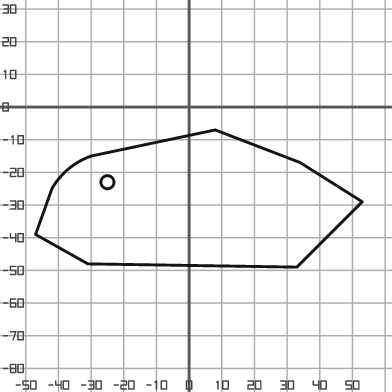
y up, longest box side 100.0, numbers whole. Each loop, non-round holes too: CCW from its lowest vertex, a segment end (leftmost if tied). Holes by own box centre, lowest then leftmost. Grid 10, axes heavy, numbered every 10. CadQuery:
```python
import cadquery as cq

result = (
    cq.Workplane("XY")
    .moveTo(33.0, -49.0)
    .lineTo(53.0, -29.0)
    .lineTo(34.0, -17.0)
    .lineTo(8.0, -7.0)
    .lineTo(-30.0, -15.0)
    .threePointArc((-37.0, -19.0), (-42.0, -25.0))
    .lineTo(-47.0, -39.0)
    .lineTo(-31.0, -48.0)
    .close()
    .moveTo(-25.0, -23.0)
    .circle(2.0)
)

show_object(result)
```